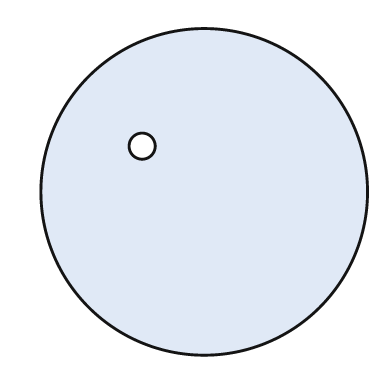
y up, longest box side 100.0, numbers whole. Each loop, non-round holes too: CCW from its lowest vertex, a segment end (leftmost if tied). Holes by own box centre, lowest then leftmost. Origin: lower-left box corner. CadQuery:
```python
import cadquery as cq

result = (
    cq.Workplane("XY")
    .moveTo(50.0, 50.0)
    .circle(50.0)
    .moveTo(31.0, 64.0)
    .circle(4.0)
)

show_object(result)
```